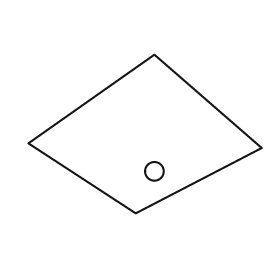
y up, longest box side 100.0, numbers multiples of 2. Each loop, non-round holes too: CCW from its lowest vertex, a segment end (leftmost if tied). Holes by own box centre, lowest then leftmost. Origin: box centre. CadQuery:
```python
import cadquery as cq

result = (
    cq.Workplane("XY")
    .moveTo(-4.0, -34.0)
    .lineTo(50.0, -6.0)
    .lineTo(4.0, 34.0)
    .lineTo(-50.0, -4.0)
    .close()
    .moveTo(4.0, -16.0)
    .circle(4.0)
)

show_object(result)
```